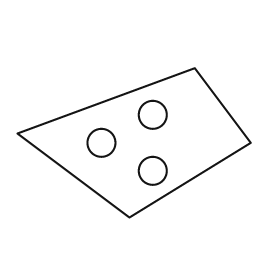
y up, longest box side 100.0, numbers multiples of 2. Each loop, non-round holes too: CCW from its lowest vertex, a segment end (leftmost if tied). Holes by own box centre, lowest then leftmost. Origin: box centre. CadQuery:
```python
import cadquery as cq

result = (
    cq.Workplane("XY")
    .moveTo(-2.0, -32.0)
    .lineTo(50.0, 0.0)
    .lineTo(26.0, 32.0)
    .lineTo(-50.0, 4.0)
    .close()
    .moveTo(8.0, -12.0)
    .circle(6.0)
    .moveTo(-14.0, 0.0)
    .circle(6.0)
    .moveTo(8.0, 12.0)
    .circle(6.0)
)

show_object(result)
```